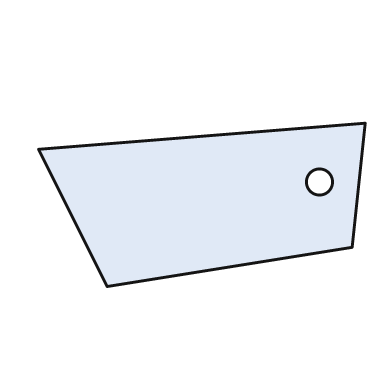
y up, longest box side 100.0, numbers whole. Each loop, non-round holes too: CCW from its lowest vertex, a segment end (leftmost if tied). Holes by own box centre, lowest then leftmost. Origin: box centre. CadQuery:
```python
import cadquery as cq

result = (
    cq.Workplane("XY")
    .moveTo(-29.0, -25.0)
    .lineTo(46.0, -13.0)
    .lineTo(50.0, 25.0)
    .lineTo(-50.0, 17.0)
    .close()
    .moveTo(36.0, 7.0)
    .circle(4.0)
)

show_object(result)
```